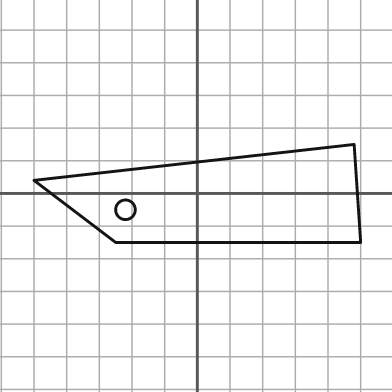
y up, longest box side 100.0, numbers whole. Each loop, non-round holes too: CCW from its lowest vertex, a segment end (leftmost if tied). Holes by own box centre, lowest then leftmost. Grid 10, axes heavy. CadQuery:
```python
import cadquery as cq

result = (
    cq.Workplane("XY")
    .moveTo(-25.0, -15.0)
    .lineTo(50.0, -15.0)
    .lineTo(48.0, 15.0)
    .lineTo(-50.0, 4.0)
    .close()
    .moveTo(-22.0, -5.0)
    .circle(3.0)
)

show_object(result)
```